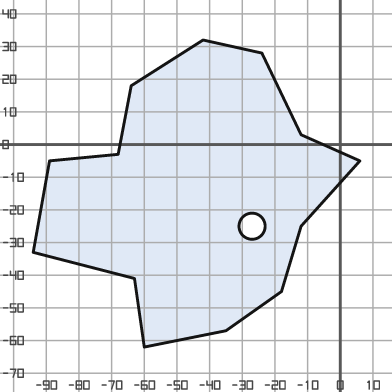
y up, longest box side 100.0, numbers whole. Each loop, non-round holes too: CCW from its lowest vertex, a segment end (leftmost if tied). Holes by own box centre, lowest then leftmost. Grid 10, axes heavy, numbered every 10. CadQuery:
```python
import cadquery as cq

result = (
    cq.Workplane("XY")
    .moveTo(-60.0, -62.0)
    .lineTo(-35.0, -57.0)
    .lineTo(-18.0, -45.0)
    .lineTo(-12.0, -25.0)
    .lineTo(6.0, -5.0)
    .lineTo(-12.0, 3.0)
    .lineTo(-24.0, 28.0)
    .lineTo(-42.0, 32.0)
    .lineTo(-64.0, 18.0)
    .lineTo(-68.0, -3.0)
    .lineTo(-89.0, -5.0)
    .lineTo(-94.0, -33.0)
    .lineTo(-63.0, -41.0)
    .close()
    .moveTo(-27.0, -25.0)
    .circle(4.0)
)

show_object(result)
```